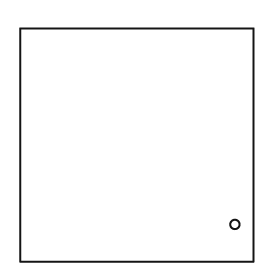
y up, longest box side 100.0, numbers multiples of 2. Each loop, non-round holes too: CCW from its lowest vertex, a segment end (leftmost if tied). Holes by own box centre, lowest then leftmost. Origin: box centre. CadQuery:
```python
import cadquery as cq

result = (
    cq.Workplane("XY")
    .moveTo(-50.0, -50.0)
    .lineTo(50.0, -50.0)
    .lineTo(50.0, 50.0)
    .lineTo(-50.0, 50.0)
    .close()
    .moveTo(42.0, -34.0)
    .circle(2.0)
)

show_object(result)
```